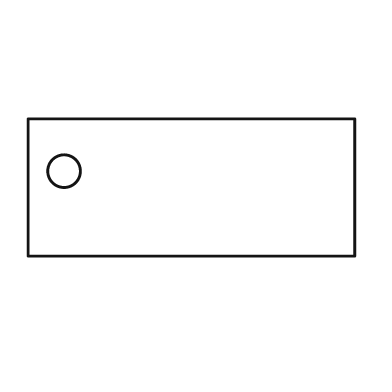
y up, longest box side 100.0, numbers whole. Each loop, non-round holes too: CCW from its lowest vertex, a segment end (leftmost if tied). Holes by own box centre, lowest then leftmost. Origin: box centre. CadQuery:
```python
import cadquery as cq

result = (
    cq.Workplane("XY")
    .moveTo(-50.0, -21.0)
    .lineTo(50.0, -21.0)
    .lineTo(50.0, 21.0)
    .lineTo(-50.0, 21.0)
    .close()
    .moveTo(-39.0, 5.0)
    .circle(5.0)
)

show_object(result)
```